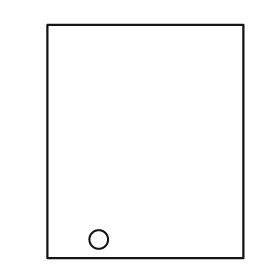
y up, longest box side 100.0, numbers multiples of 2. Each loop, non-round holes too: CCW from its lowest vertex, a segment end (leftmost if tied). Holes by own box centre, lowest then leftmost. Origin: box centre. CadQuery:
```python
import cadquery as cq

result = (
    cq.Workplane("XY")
    .moveTo(-42.0, -50.0)
    .lineTo(42.0, -50.0)
    .lineTo(42.0, 50.0)
    .lineTo(-42.0, 50.0)
    .close()
    .moveTo(-20.0, -42.0)
    .circle(4.0)
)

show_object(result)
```